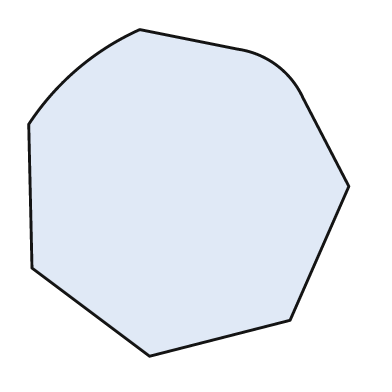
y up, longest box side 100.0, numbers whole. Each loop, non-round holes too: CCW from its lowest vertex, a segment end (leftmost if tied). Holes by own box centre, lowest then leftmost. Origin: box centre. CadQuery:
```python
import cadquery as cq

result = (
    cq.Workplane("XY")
    .moveTo(-12.0, -50.0)
    .lineTo(31.0, -39.0)
    .lineTo(49.0, 2.0)
    .lineTo(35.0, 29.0)
    .threePointArc((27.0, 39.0), (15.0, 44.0))
    .lineTo(-15.0, 50.0)
    .threePointArc((-34.0, 38.0), (-49.0, 21.0))
    .lineTo(-48.0, -23.0)
    .close()
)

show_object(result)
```